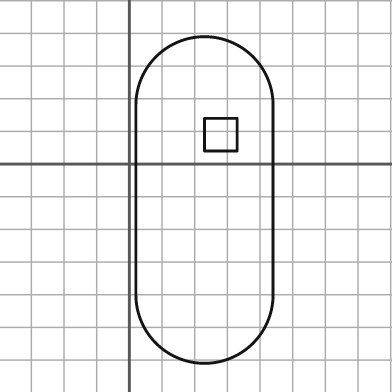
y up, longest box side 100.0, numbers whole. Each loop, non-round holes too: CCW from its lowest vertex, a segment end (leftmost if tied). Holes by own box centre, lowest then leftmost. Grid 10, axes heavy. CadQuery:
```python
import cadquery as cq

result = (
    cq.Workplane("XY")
    .moveTo(2.0, -40.0)
    .threePointArc((23.0, -61.0), (44.0, -40.0))
    .lineTo(44.0, 18.0)
    .threePointArc((23.0, 39.0), (2.0, 18.0))
    .close()
    .moveTo(23.0, 4.0)
    .lineTo(33.0, 4.0)
    .lineTo(33.0, 14.0)
    .lineTo(23.0, 14.0)
    .close()
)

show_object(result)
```